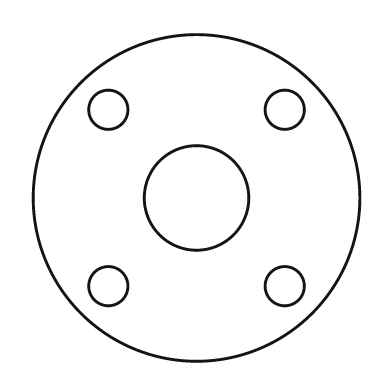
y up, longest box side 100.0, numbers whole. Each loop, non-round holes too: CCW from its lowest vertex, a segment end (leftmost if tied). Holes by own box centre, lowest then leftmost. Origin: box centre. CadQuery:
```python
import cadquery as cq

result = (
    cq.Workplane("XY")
    .moveTo(0.0, 0.0)
    .circle(50.0)
    .moveTo(-27.0, -27.0)
    .circle(6.0)
    .moveTo(27.0, -27.0)
    .circle(6.0)
    .moveTo(0.0, 0.0)
    .circle(16.0)
    .moveTo(-27.0, 27.0)
    .circle(6.0)
    .moveTo(27.0, 27.0)
    .circle(6.0)
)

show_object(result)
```